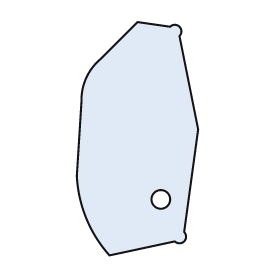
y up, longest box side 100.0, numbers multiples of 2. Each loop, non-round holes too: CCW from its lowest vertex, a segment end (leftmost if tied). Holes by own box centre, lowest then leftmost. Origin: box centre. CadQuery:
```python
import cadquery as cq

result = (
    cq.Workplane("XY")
    .moveTo(-12.0, -50.0)
    .lineTo(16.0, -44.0)
    .threePointArc((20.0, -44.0), (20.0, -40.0))
    .lineTo(26.0, 4.0)
    .lineTo(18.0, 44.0)
    .threePointArc((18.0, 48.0), (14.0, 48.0))
    .lineTo(0.0, 50.0)
    .lineTo(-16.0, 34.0)
    .threePointArc((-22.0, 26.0), (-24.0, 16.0))
    .lineTo(-26.0, -16.0)
    .threePointArc((-22.0, -34.0), (-12.0, -50.0))
    .close()
    .moveTo(10.0, -26.0)
    .circle(4.0)
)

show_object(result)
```